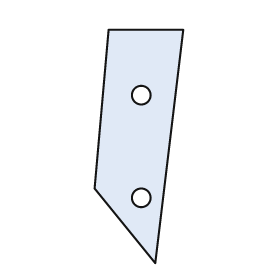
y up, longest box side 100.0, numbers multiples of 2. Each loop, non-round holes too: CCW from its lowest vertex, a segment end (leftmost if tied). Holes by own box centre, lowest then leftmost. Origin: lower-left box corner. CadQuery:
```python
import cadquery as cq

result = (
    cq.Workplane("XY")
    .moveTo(26.0, 0.0)
    .lineTo(38.0, 100.0)
    .lineTo(6.0, 100.0)
    .lineTo(0.0, 32.0)
    .close()
    .moveTo(20.0, 28.0)
    .circle(4.0)
    .moveTo(20.0, 72.0)
    .circle(4.0)
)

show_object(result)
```